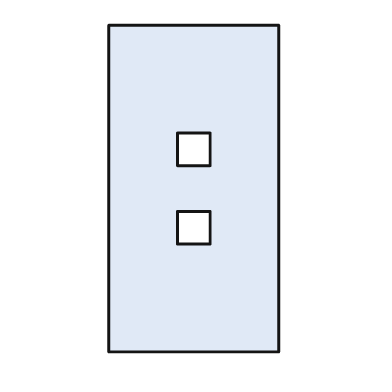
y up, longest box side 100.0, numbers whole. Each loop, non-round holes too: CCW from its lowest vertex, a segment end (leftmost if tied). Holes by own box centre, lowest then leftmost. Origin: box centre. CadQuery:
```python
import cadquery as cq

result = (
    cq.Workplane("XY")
    .moveTo(-26.0, -50.0)
    .lineTo(26.0, -50.0)
    .lineTo(26.0, 50.0)
    .lineTo(-26.0, 50.0)
    .close()
    .moveTo(-5.0, -17.0)
    .lineTo(5.0, -17.0)
    .lineTo(5.0, -7.0)
    .lineTo(-5.0, -7.0)
    .close()
    .moveTo(-5.0, 7.0)
    .lineTo(5.0, 7.0)
    .lineTo(5.0, 17.0)
    .lineTo(-5.0, 17.0)
    .close()
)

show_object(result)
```